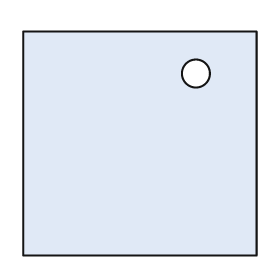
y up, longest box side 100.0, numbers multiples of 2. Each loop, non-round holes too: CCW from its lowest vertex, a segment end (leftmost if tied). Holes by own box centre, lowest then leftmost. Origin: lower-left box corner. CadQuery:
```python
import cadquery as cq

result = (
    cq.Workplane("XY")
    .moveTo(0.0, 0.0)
    .lineTo(100.0, 0.0)
    .lineTo(100.0, 96.0)
    .lineTo(0.0, 96.0)
    .close()
    .moveTo(74.0, 78.0)
    .circle(6.0)
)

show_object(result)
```